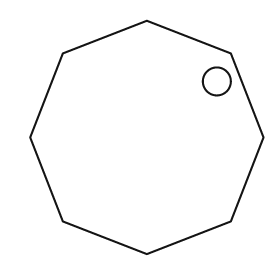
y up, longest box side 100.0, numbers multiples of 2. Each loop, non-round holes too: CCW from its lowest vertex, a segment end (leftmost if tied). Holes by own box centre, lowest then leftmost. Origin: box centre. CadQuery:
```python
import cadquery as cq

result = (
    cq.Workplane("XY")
    .moveTo(0.0, -50.0)
    .lineTo(36.0, -36.0)
    .lineTo(50.0, 0.0)
    .lineTo(36.0, 36.0)
    .lineTo(0.0, 50.0)
    .lineTo(-36.0, 36.0)
    .lineTo(-50.0, 0.0)
    .lineTo(-36.0, -36.0)
    .close()
    .moveTo(30.0, 24.0)
    .circle(6.0)
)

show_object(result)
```